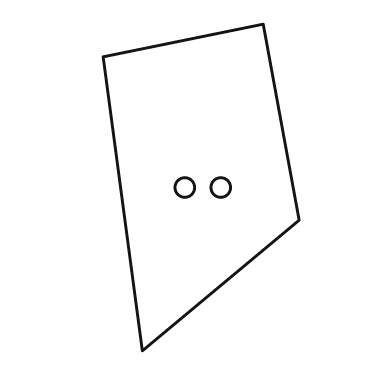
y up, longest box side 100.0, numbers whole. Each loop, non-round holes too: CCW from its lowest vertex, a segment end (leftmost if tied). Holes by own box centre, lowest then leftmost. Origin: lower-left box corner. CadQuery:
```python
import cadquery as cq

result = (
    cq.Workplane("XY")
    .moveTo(12.0, 0.0)
    .lineTo(60.0, 40.0)
    .lineTo(49.0, 100.0)
    .lineTo(0.0, 90.0)
    .close()
    .moveTo(25.0, 50.0)
    .circle(3.0)
    .moveTo(36.0, 50.0)
    .circle(3.0)
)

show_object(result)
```